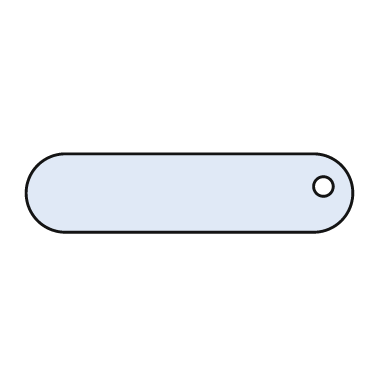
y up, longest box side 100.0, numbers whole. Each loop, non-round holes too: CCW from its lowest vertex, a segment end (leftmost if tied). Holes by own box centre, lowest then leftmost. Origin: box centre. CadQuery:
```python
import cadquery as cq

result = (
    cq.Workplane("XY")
    .moveTo(-38.0, -12.0)
    .lineTo(38.0, -12.0)
    .threePointArc((50.0, 0.0), (38.0, 12.0))
    .lineTo(-38.0, 12.0)
    .threePointArc((-50.0, 0.0), (-38.0, -12.0))
    .close()
    .moveTo(41.0, 2.0)
    .circle(3.0)
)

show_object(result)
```